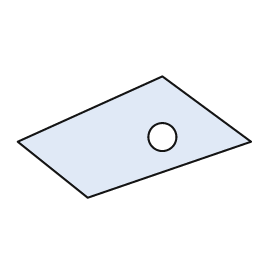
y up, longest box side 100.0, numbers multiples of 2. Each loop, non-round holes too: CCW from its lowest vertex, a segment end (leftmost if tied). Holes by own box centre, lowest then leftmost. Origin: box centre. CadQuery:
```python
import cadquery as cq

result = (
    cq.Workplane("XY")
    .moveTo(-20.0, -26.0)
    .lineTo(50.0, -2.0)
    .lineTo(12.0, 26.0)
    .lineTo(-50.0, -2.0)
    .close()
    .moveTo(12.0, 0.0)
    .circle(6.0)
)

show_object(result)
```